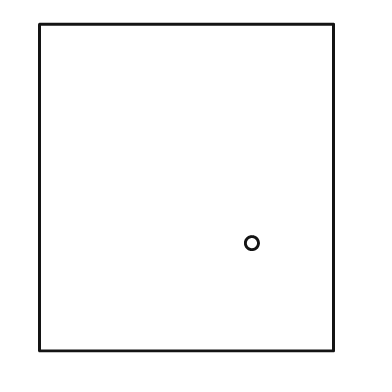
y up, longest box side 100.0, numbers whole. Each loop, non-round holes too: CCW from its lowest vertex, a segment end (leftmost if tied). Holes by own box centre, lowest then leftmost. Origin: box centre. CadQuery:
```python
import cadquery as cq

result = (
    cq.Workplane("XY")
    .moveTo(-45.0, -50.0)
    .lineTo(45.0, -50.0)
    .lineTo(45.0, 50.0)
    .lineTo(-45.0, 50.0)
    .close()
    .moveTo(20.0, -17.0)
    .circle(2.0)
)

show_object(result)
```